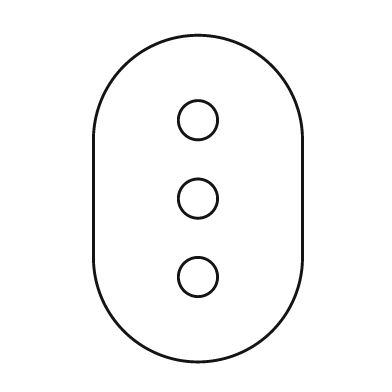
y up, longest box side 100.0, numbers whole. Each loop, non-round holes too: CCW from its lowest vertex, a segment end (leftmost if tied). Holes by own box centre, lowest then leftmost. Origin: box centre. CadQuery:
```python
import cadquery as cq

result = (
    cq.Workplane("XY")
    .moveTo(-32.0, -18.0)
    .threePointArc((0.0, -50.0), (32.0, -18.0))
    .lineTo(32.0, 18.0)
    .threePointArc((0.0, 50.0), (-32.0, 18.0))
    .close()
    .moveTo(0.0, -24.0)
    .circle(6.0)
    .moveTo(0.0, 0.0)
    .circle(6.0)
    .moveTo(0.0, 24.0)
    .circle(6.0)
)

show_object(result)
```